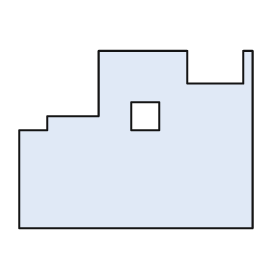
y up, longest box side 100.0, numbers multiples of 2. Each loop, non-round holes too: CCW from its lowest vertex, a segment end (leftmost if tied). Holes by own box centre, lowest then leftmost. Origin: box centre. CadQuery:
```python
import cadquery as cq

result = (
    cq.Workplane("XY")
    .moveTo(-50.0, -38.0)
    .lineTo(50.0, -38.0)
    .lineTo(50.0, 38.0)
    .lineTo(46.0, 38.0)
    .lineTo(46.0, 24.0)
    .lineTo(22.0, 24.0)
    .lineTo(22.0, 38.0)
    .lineTo(-16.0, 38.0)
    .lineTo(-16.0, 10.0)
    .lineTo(-38.0, 10.0)
    .lineTo(-38.0, 4.0)
    .lineTo(-50.0, 4.0)
    .close()
    .moveTo(-2.0, 4.0)
    .lineTo(10.0, 4.0)
    .lineTo(10.0, 16.0)
    .lineTo(-2.0, 16.0)
    .close()
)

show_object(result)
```